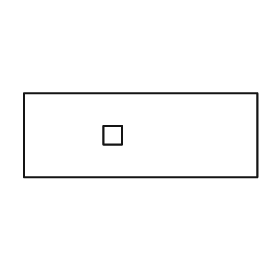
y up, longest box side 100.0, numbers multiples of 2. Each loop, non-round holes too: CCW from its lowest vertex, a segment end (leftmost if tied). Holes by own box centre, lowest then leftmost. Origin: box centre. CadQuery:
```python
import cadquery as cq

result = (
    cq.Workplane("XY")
    .moveTo(-50.0, -18.0)
    .lineTo(50.0, -18.0)
    .lineTo(50.0, 18.0)
    .lineTo(-50.0, 18.0)
    .close()
    .moveTo(-16.0, -4.0)
    .lineTo(-8.0, -4.0)
    .lineTo(-8.0, 4.0)
    .lineTo(-16.0, 4.0)
    .close()
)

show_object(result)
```